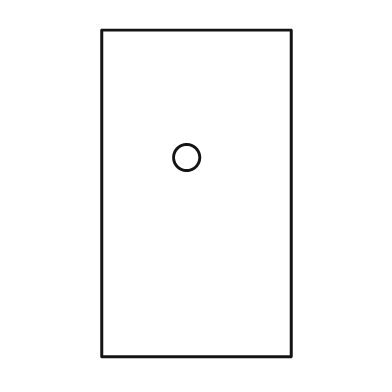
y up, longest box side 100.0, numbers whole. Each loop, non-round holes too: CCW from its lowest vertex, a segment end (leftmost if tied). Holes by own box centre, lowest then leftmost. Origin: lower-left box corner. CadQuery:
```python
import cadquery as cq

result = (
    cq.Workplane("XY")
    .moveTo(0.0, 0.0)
    .lineTo(58.0, 0.0)
    .lineTo(58.0, 100.0)
    .lineTo(0.0, 100.0)
    .close()
    .moveTo(26.0, 61.0)
    .circle(4.0)
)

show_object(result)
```